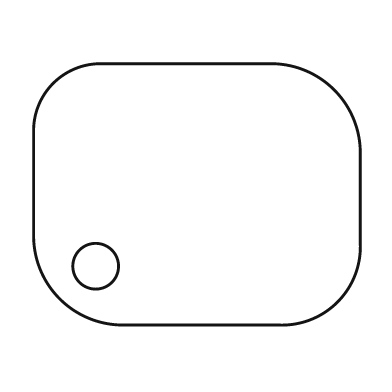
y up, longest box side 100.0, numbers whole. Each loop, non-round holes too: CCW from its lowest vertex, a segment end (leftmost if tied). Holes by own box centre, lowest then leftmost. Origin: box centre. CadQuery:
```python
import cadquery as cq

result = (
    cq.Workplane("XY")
    .moveTo(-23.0, -40.0)
    .lineTo(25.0, -40.0)
    .threePointArc((43.0, -33.0), (50.0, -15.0))
    .lineTo(50.0, 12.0)
    .threePointArc((42.0, 32.0), (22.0, 40.0))
    .lineTo(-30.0, 40.0)
    .threePointArc((-44.0, 34.0), (-50.0, 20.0))
    .lineTo(-50.0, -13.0)
    .threePointArc((-42.0, -32.0), (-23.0, -40.0))
    .close()
    .moveTo(-31.0, -22.0)
    .circle(7.0)
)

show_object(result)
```